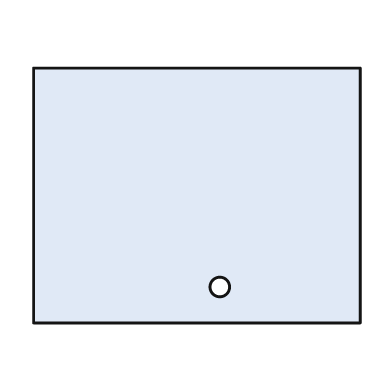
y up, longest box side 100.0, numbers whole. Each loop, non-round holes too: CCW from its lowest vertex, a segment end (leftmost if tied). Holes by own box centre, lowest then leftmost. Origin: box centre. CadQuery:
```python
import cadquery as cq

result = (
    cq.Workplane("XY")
    .moveTo(-50.0, -39.0)
    .lineTo(50.0, -39.0)
    .lineTo(50.0, 39.0)
    .lineTo(-50.0, 39.0)
    .close()
    .moveTo(7.0, -28.0)
    .circle(3.0)
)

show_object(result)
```